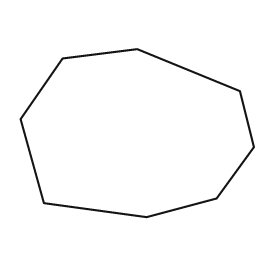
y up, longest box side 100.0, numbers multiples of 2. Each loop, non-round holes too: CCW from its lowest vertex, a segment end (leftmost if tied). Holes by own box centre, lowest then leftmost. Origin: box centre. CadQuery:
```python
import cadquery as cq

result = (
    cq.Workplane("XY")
    .moveTo(4.0, -36.0)
    .lineTo(34.0, -28.0)
    .lineTo(50.0, -6.0)
    .lineTo(44.0, 18.0)
    .lineTo(0.0, 36.0)
    .lineTo(-32.0, 32.0)
    .lineTo(-50.0, 6.0)
    .lineTo(-40.0, -30.0)
    .close()
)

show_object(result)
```